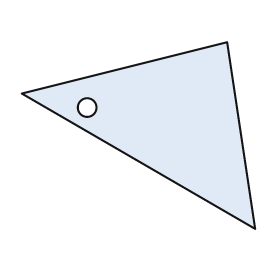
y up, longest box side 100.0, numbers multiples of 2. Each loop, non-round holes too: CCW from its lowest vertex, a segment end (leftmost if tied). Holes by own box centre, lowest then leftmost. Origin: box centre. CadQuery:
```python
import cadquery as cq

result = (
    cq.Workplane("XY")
    .moveTo(50.0, -40.0)
    .lineTo(38.0, 40.0)
    .lineTo(-50.0, 18.0)
    .close()
    .moveTo(-22.0, 12.0)
    .circle(4.0)
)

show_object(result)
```